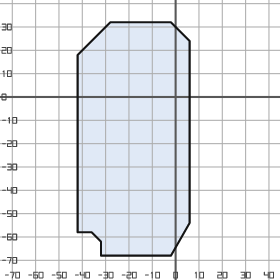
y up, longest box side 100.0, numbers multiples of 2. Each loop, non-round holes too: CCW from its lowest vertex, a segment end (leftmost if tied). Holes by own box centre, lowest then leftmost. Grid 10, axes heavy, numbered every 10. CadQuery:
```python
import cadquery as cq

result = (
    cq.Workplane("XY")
    .moveTo(-32.0, -68.0)
    .lineTo(-2.0, -68.0)
    .lineTo(6.0, -54.0)
    .lineTo(6.0, 24.0)
    .lineTo(-2.0, 32.0)
    .lineTo(-28.0, 32.0)
    .lineTo(-42.0, 18.0)
    .lineTo(-42.0, -58.0)
    .lineTo(-36.0, -58.0)
    .lineTo(-32.0, -62.0)
    .close()
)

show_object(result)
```